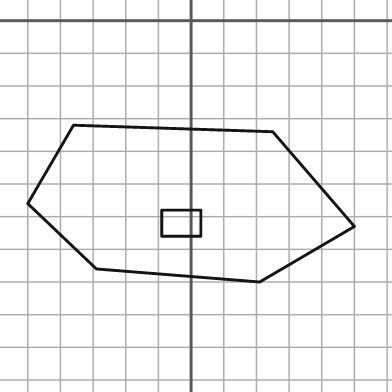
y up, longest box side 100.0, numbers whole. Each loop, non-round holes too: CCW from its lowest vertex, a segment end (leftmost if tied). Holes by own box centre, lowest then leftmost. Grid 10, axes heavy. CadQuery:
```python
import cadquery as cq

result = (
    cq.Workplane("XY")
    .moveTo(21.0, -80.0)
    .lineTo(50.0, -63.0)
    .lineTo(25.0, -34.0)
    .lineTo(-36.0, -32.0)
    .lineTo(-50.0, -56.0)
    .lineTo(-29.0, -76.0)
    .close()
    .moveTo(-9.0, -66.0)
    .lineTo(3.0, -66.0)
    .lineTo(3.0, -58.0)
    .lineTo(-9.0, -58.0)
    .close()
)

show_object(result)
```